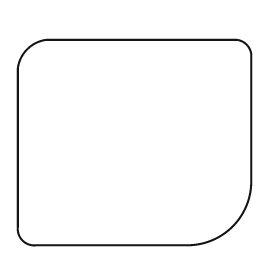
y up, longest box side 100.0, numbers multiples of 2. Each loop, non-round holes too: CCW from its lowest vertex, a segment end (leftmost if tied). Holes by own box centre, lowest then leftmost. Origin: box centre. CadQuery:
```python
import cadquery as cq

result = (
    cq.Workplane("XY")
    .moveTo(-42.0, -44.0)
    .lineTo(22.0, -44.0)
    .threePointArc((42.0, -36.0), (50.0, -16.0))
    .lineTo(50.0, 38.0)
    .threePointArc((48.0, 42.0), (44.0, 44.0))
    .lineTo(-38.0, 44.0)
    .threePointArc((-46.0, 40.0), (-50.0, 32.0))
    .lineTo(-50.0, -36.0)
    .threePointArc((-48.0, -42.0), (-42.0, -44.0))
    .close()
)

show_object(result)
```